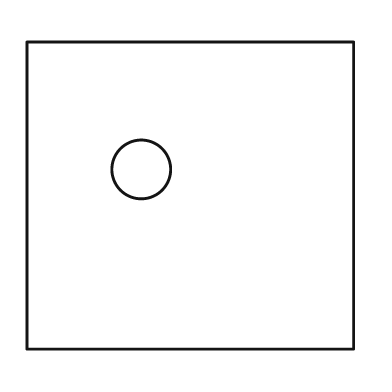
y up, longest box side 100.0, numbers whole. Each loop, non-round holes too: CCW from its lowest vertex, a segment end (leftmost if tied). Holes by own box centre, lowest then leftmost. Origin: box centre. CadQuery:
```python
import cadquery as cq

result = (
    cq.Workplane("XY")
    .moveTo(-50.0, -47.0)
    .lineTo(50.0, -47.0)
    .lineTo(50.0, 47.0)
    .lineTo(-50.0, 47.0)
    .close()
    .moveTo(-15.0, 8.0)
    .circle(9.0)
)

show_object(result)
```